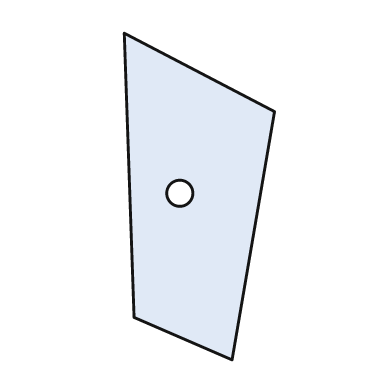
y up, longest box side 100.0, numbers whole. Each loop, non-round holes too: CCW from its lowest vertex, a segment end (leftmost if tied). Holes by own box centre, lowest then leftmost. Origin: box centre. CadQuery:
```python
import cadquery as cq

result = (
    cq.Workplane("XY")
    .moveTo(10.0, -50.0)
    .lineTo(23.0, 26.0)
    .lineTo(-23.0, 50.0)
    .lineTo(-20.0, -37.0)
    .close()
    .moveTo(-6.0, 1.0)
    .circle(4.0)
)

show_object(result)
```